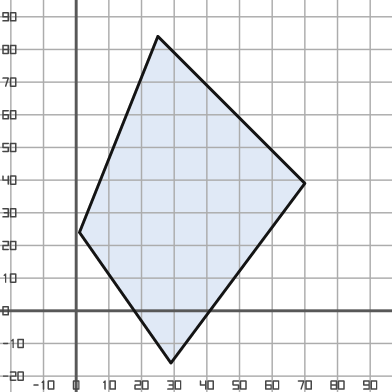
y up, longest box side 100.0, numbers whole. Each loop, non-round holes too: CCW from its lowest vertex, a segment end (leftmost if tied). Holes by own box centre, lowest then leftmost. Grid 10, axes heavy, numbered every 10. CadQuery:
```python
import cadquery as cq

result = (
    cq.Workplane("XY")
    .moveTo(29.0, -16.0)
    .lineTo(70.0, 39.0)
    .lineTo(25.0, 84.0)
    .lineTo(1.0, 24.0)
    .close()
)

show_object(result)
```